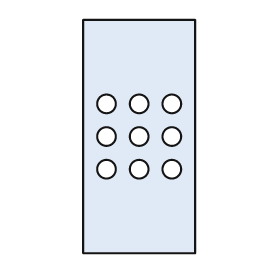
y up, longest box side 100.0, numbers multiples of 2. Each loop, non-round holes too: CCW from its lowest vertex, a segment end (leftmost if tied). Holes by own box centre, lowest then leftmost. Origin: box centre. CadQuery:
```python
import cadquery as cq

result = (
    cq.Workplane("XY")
    .moveTo(-24.0, -50.0)
    .lineTo(24.0, -50.0)
    .lineTo(24.0, 50.0)
    .lineTo(-24.0, 50.0)
    .close()
    .moveTo(-14.0, -14.0)
    .circle(4.0)
    .moveTo(0.0, -14.0)
    .circle(4.0)
    .moveTo(14.0, -14.0)
    .circle(4.0)
    .moveTo(-14.0, 0.0)
    .circle(4.0)
    .moveTo(0.0, 0.0)
    .circle(4.0)
    .moveTo(14.0, 0.0)
    .circle(4.0)
    .moveTo(-14.0, 14.0)
    .circle(4.0)
    .moveTo(0.0, 14.0)
    .circle(4.0)
    .moveTo(14.0, 14.0)
    .circle(4.0)
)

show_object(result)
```